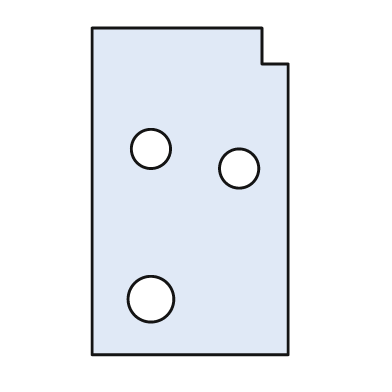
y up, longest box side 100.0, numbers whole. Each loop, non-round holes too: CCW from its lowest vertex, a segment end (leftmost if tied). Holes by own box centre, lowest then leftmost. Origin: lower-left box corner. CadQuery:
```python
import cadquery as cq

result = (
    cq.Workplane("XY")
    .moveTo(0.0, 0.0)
    .lineTo(60.0, 0.0)
    .lineTo(60.0, 89.0)
    .lineTo(52.0, 89.0)
    .lineTo(52.0, 100.0)
    .lineTo(0.0, 100.0)
    .close()
    .moveTo(18.0, 17.0)
    .circle(7.0)
    .moveTo(45.0, 57.0)
    .circle(6.0)
    .moveTo(18.0, 63.0)
    .circle(6.0)
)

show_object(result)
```